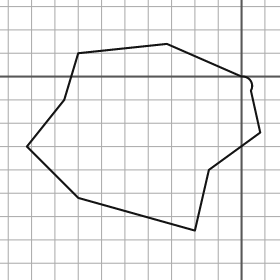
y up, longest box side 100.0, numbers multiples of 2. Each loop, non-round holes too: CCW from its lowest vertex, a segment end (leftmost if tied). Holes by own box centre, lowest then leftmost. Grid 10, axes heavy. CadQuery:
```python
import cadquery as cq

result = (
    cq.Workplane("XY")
    .moveTo(-20.0, -66.0)
    .lineTo(-14.0, -40.0)
    .lineTo(8.0, -24.0)
    .lineTo(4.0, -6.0)
    .threePointArc((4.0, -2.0), (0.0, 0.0))
    .lineTo(-32.0, 14.0)
    .lineTo(-70.0, 10.0)
    .lineTo(-76.0, -10.0)
    .lineTo(-92.0, -30.0)
    .lineTo(-70.0, -52.0)
    .close()
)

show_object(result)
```